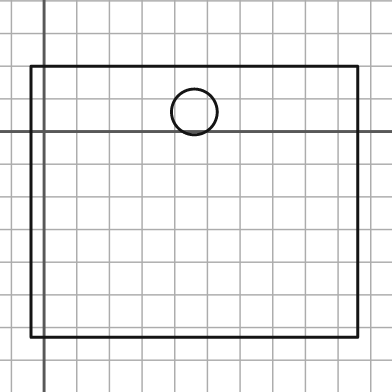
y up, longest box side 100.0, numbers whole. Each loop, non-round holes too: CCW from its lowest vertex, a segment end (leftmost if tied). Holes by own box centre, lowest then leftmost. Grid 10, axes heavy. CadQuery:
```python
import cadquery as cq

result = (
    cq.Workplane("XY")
    .moveTo(-4.0, -63.0)
    .lineTo(96.0, -63.0)
    .lineTo(96.0, 20.0)
    .lineTo(-4.0, 20.0)
    .close()
    .moveTo(46.0, 6.0)
    .circle(7.0)
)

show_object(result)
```